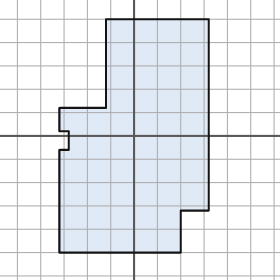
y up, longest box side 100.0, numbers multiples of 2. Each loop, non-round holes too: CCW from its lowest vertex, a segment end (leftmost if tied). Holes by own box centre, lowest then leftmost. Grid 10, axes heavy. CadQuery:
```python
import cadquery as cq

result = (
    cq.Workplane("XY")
    .moveTo(-32.0, -50.0)
    .lineTo(20.0, -50.0)
    .lineTo(20.0, -32.0)
    .lineTo(32.0, -32.0)
    .lineTo(32.0, 50.0)
    .lineTo(-12.0, 50.0)
    .lineTo(-12.0, 12.0)
    .lineTo(-32.0, 12.0)
    .lineTo(-32.0, 2.0)
    .lineTo(-28.0, 2.0)
    .lineTo(-28.0, -6.0)
    .lineTo(-32.0, -6.0)
    .close()
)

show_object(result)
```